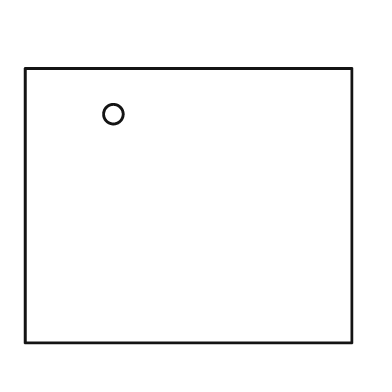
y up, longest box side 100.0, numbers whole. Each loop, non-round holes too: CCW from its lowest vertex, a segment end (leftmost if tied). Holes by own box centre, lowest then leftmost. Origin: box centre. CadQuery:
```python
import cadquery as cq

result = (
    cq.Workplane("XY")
    .moveTo(-50.0, -42.0)
    .lineTo(50.0, -42.0)
    .lineTo(50.0, 42.0)
    .lineTo(-50.0, 42.0)
    .close()
    .moveTo(-23.0, 28.0)
    .circle(3.0)
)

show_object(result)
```